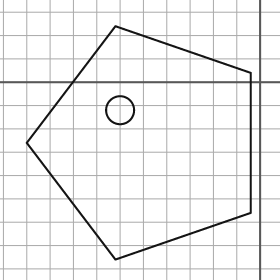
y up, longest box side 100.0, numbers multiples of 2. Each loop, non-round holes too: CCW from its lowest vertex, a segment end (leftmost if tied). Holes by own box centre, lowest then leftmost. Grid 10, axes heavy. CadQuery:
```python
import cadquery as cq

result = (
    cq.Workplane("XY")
    .moveTo(-62.0, -76.0)
    .lineTo(-4.0, -56.0)
    .lineTo(-4.0, 4.0)
    .lineTo(-62.0, 24.0)
    .lineTo(-100.0, -26.0)
    .close()
    .moveTo(-60.0, -12.0)
    .circle(6.0)
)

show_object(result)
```